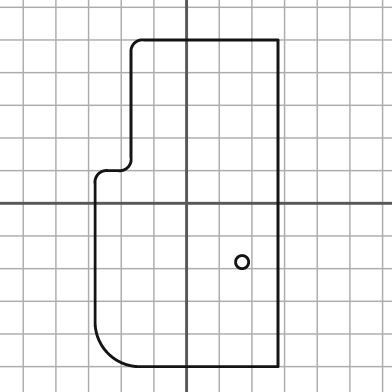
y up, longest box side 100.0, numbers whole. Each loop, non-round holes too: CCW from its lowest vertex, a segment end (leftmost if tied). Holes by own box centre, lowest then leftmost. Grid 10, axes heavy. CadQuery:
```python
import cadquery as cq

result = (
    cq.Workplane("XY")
    .moveTo(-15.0, -50.0)
    .lineTo(28.0, -50.0)
    .lineTo(28.0, 50.0)
    .lineTo(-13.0, 50.0)
    .threePointArc((-16.0, 49.0), (-17.0, 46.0))
    .lineTo(-17.0, 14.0)
    .threePointArc((-18.0, 11.0), (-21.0, 10.0))
    .lineTo(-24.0, 10.0)
    .threePointArc((-27.0, 9.0), (-28.0, 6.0))
    .lineTo(-28.0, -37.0)
    .threePointArc((-24.0, -46.0), (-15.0, -50.0))
    .close()
    .moveTo(17.0, -18.0)
    .circle(2.0)
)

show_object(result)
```